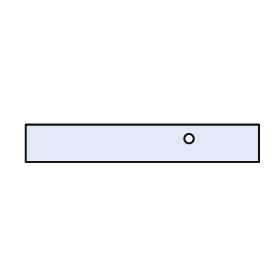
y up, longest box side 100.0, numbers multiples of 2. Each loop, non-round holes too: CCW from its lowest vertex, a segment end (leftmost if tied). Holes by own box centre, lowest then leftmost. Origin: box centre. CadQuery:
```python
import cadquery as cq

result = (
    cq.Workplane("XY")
    .moveTo(-50.0, -8.0)
    .lineTo(50.0, -8.0)
    .lineTo(50.0, 8.0)
    .lineTo(-50.0, 8.0)
    .close()
    .moveTo(20.0, 2.0)
    .circle(2.0)
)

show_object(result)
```